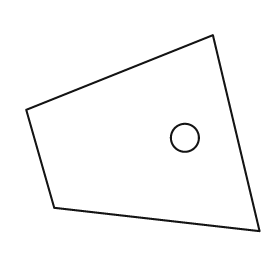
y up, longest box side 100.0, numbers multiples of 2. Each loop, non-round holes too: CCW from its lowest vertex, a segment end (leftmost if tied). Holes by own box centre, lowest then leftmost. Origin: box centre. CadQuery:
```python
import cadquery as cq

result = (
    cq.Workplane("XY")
    .moveTo(50.0, -42.0)
    .lineTo(30.0, 42.0)
    .lineTo(-50.0, 10.0)
    .lineTo(-38.0, -32.0)
    .close()
    .moveTo(18.0, -2.0)
    .circle(6.0)
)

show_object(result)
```